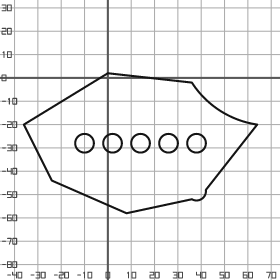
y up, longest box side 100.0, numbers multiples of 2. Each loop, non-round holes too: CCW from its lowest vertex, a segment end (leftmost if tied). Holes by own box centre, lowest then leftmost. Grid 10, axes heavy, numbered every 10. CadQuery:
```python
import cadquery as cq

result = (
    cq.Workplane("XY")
    .moveTo(8.0, -58.0)
    .lineTo(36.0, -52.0)
    .threePointArc((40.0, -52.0), (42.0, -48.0))
    .lineTo(64.0, -20.0)
    .threePointArc((48.0, -14.0), (36.0, -2.0))
    .lineTo(0.0, 2.0)
    .lineTo(-36.0, -20.0)
    .lineTo(-24.0, -44.0)
    .close()
    .moveTo(-10.0, -28.0)
    .circle(4.0)
    .moveTo(2.0, -28.0)
    .circle(4.0)
    .moveTo(14.0, -28.0)
    .circle(4.0)
    .moveTo(26.0, -28.0)
    .circle(4.0)
    .moveTo(38.0, -28.0)
    .circle(4.0)
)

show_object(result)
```